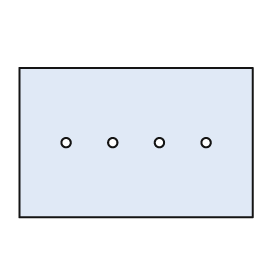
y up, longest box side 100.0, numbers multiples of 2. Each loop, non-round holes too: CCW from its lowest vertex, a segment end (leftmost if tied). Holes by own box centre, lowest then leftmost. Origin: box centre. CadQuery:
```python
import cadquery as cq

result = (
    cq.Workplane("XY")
    .moveTo(-50.0, -32.0)
    .lineTo(50.0, -32.0)
    .lineTo(50.0, 32.0)
    .lineTo(-50.0, 32.0)
    .close()
    .moveTo(-30.0, 0.0)
    .circle(2.0)
    .moveTo(-10.0, 0.0)
    .circle(2.0)
    .moveTo(10.0, 0.0)
    .circle(2.0)
    .moveTo(30.0, 0.0)
    .circle(2.0)
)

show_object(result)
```